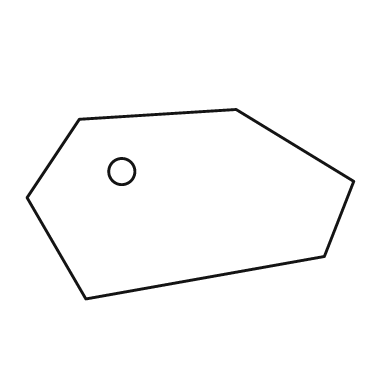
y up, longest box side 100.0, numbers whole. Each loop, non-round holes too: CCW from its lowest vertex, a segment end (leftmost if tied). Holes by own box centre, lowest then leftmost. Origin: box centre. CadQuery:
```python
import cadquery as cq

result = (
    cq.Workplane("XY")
    .moveTo(-32.0, -29.0)
    .lineTo(41.0, -16.0)
    .lineTo(50.0, 7.0)
    .lineTo(14.0, 29.0)
    .lineTo(-34.0, 26.0)
    .lineTo(-50.0, 2.0)
    .close()
    .moveTo(-21.0, 10.0)
    .circle(4.0)
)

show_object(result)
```